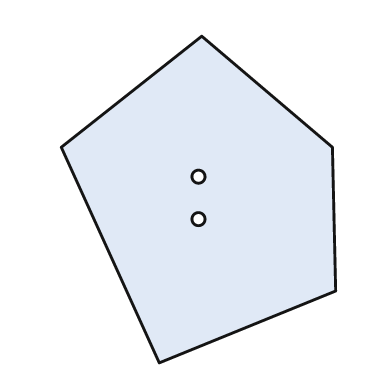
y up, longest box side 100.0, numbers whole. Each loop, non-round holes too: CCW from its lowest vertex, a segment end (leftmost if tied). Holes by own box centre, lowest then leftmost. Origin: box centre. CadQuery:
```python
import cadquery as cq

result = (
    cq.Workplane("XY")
    .moveTo(-12.0, -50.0)
    .lineTo(42.0, -28.0)
    .lineTo(41.0, 16.0)
    .lineTo(1.0, 50.0)
    .lineTo(-42.0, 16.0)
    .close()
    .moveTo(0.0, -6.0)
    .circle(2.0)
    .moveTo(0.0, 7.0)
    .circle(2.0)
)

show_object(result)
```